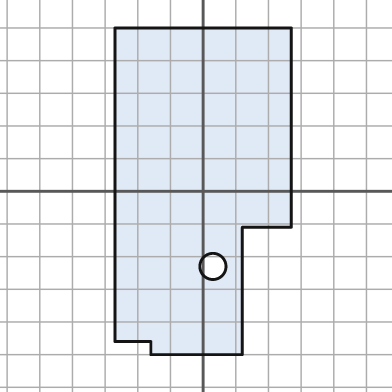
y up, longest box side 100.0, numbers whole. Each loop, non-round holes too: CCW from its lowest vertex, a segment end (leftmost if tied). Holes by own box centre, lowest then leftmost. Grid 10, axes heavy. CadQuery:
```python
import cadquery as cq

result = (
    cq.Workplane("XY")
    .moveTo(-16.0, -50.0)
    .lineTo(12.0, -50.0)
    .lineTo(12.0, -11.0)
    .lineTo(27.0, -11.0)
    .lineTo(27.0, 50.0)
    .lineTo(-27.0, 50.0)
    .lineTo(-27.0, -46.0)
    .lineTo(-16.0, -46.0)
    .close()
    .moveTo(3.0, -23.0)
    .circle(4.0)
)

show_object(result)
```